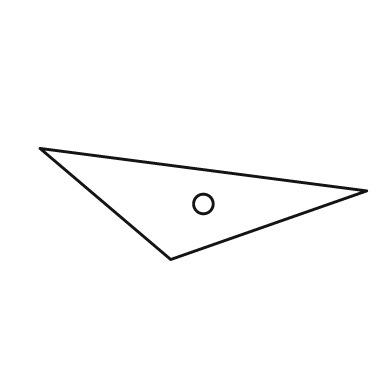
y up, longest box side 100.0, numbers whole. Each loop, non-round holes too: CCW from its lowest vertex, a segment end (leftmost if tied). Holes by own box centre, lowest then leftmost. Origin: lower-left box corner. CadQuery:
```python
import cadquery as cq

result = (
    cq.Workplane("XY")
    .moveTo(40.0, 0.0)
    .lineTo(100.0, 21.0)
    .lineTo(0.0, 34.0)
    .close()
    .moveTo(50.0, 17.0)
    .circle(3.0)
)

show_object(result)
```